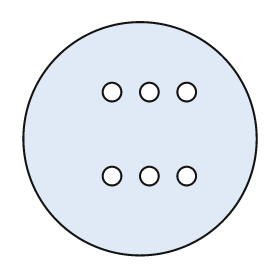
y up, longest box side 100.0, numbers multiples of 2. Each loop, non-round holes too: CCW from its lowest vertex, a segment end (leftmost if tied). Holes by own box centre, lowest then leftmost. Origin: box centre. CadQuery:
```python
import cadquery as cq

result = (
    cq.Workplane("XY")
    .moveTo(0.0, 0.0)
    .circle(50.0)
    .moveTo(-12.0, -16.0)
    .circle(4.0)
    .moveTo(4.0, -16.0)
    .circle(4.0)
    .moveTo(20.0, -16.0)
    .circle(4.0)
    .moveTo(-12.0, 20.0)
    .circle(4.0)
    .moveTo(4.0, 20.0)
    .circle(4.0)
    .moveTo(20.0, 20.0)
    .circle(4.0)
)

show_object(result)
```